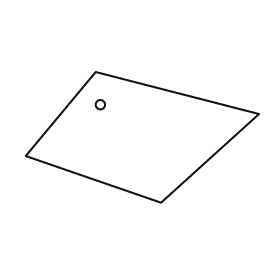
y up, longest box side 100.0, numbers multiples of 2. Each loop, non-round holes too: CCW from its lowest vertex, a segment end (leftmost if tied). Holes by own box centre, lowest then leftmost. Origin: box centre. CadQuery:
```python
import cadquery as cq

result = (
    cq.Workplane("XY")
    .moveTo(8.0, -28.0)
    .lineTo(50.0, 10.0)
    .lineTo(-20.0, 28.0)
    .lineTo(-50.0, -8.0)
    .close()
    .moveTo(-18.0, 14.0)
    .circle(2.0)
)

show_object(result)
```